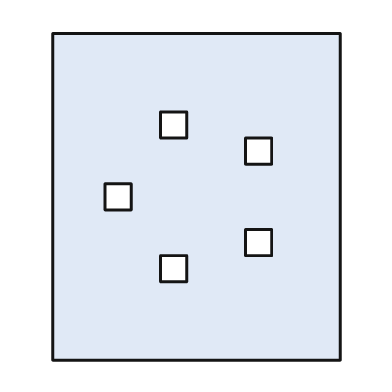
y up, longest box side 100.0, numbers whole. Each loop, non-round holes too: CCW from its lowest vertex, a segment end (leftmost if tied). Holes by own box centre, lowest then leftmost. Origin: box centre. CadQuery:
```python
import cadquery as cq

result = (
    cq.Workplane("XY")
    .moveTo(-44.0, -50.0)
    .lineTo(44.0, -50.0)
    .lineTo(44.0, 50.0)
    .lineTo(-44.0, 50.0)
    .close()
    .moveTo(-11.0, -26.0)
    .lineTo(-3.0, -26.0)
    .lineTo(-3.0, -18.0)
    .lineTo(-11.0, -18.0)
    .close()
    .moveTo(15.0, -18.0)
    .lineTo(23.0, -18.0)
    .lineTo(23.0, -10.0)
    .lineTo(15.0, -10.0)
    .close()
    .moveTo(-28.0, -4.0)
    .lineTo(-20.0, -4.0)
    .lineTo(-20.0, 4.0)
    .lineTo(-28.0, 4.0)
    .close()
    .moveTo(15.0, 10.0)
    .lineTo(23.0, 10.0)
    .lineTo(23.0, 18.0)
    .lineTo(15.0, 18.0)
    .close()
    .moveTo(-11.0, 18.0)
    .lineTo(-3.0, 18.0)
    .lineTo(-3.0, 26.0)
    .lineTo(-11.0, 26.0)
    .close()
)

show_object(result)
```